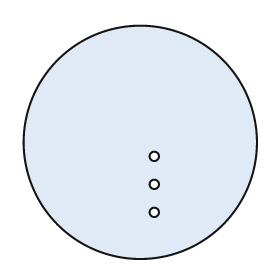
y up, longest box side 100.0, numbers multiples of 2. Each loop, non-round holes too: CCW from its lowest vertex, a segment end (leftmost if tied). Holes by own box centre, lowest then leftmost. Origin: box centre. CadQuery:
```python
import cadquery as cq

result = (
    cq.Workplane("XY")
    .moveTo(0.0, 0.0)
    .circle(50.0)
    .moveTo(6.0, -30.0)
    .circle(2.0)
    .moveTo(6.0, -18.0)
    .circle(2.0)
    .moveTo(6.0, -6.0)
    .circle(2.0)
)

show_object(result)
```